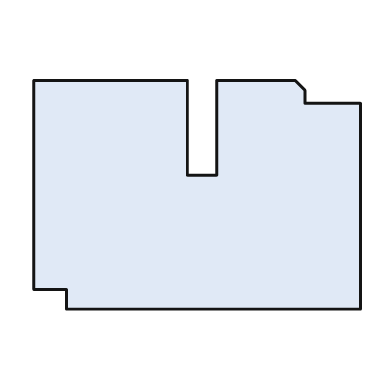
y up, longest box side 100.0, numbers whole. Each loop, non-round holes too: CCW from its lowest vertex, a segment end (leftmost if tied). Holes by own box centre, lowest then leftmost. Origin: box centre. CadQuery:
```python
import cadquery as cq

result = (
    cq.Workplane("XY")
    .moveTo(-40.0, -35.0)
    .lineTo(50.0, -35.0)
    .lineTo(50.0, 28.0)
    .lineTo(33.0, 28.0)
    .lineTo(33.0, 32.0)
    .lineTo(30.0, 35.0)
    .lineTo(6.0, 35.0)
    .lineTo(6.0, 6.0)
    .lineTo(-3.0, 6.0)
    .lineTo(-3.0, 35.0)
    .lineTo(-50.0, 35.0)
    .lineTo(-50.0, -29.0)
    .lineTo(-40.0, -29.0)
    .close()
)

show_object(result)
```